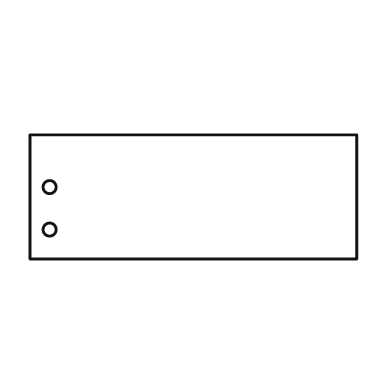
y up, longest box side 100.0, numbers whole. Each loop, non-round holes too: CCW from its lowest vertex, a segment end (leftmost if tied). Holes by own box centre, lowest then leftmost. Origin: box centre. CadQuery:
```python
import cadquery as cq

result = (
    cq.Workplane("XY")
    .moveTo(-50.0, -19.0)
    .lineTo(50.0, -19.0)
    .lineTo(50.0, 19.0)
    .lineTo(-50.0, 19.0)
    .close()
    .moveTo(-44.0, -10.0)
    .circle(2.0)
    .moveTo(-44.0, 3.0)
    .circle(2.0)
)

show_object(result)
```